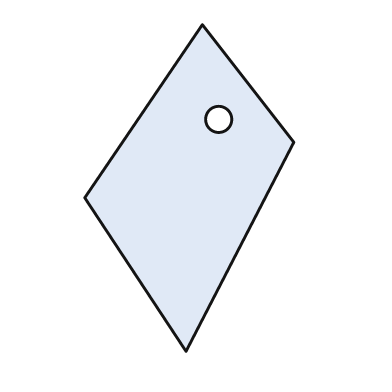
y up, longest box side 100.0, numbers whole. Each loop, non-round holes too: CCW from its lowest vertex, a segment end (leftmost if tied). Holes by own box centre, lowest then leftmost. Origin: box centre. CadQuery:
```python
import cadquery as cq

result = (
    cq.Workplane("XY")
    .moveTo(-1.0, -50.0)
    .lineTo(32.0, 14.0)
    .lineTo(4.0, 50.0)
    .lineTo(-32.0, -3.0)
    .close()
    .moveTo(9.0, 21.0)
    .circle(4.0)
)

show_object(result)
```